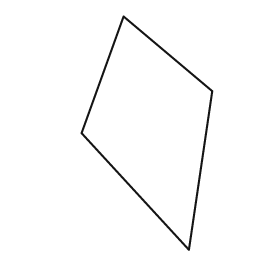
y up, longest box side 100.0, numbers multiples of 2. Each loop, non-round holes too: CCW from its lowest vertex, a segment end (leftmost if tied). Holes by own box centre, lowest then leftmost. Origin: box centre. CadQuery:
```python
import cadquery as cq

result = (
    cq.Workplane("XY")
    .moveTo(18.0, -50.0)
    .lineTo(28.0, 18.0)
    .lineTo(-10.0, 50.0)
    .lineTo(-28.0, 0.0)
    .close()
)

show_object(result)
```